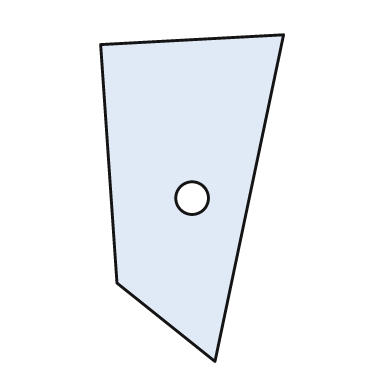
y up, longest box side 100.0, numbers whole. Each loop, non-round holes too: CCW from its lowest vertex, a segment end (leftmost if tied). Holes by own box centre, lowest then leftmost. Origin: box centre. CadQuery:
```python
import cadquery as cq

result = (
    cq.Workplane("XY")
    .moveTo(7.0, -50.0)
    .lineTo(28.0, 50.0)
    .lineTo(-28.0, 47.0)
    .lineTo(-23.0, -26.0)
    .close()
    .moveTo(0.0, 0.0)
    .circle(5.0)
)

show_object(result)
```